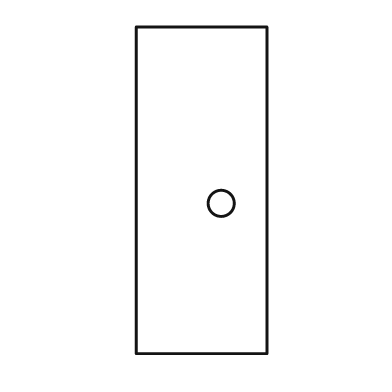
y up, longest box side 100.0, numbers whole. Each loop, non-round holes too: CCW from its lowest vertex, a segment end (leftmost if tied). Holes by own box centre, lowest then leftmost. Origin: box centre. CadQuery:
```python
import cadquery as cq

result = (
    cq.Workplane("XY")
    .moveTo(-20.0, -50.0)
    .lineTo(20.0, -50.0)
    .lineTo(20.0, 50.0)
    .lineTo(-20.0, 50.0)
    .close()
    .moveTo(6.0, -4.0)
    .circle(4.0)
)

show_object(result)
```